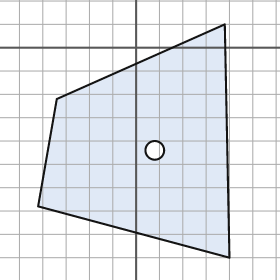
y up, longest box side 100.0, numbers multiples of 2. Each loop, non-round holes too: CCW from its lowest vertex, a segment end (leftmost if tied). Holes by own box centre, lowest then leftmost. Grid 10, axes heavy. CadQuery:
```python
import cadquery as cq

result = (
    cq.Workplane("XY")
    .moveTo(40.0, -90.0)
    .lineTo(38.0, 10.0)
    .lineTo(-34.0, -22.0)
    .lineTo(-42.0, -68.0)
    .close()
    .moveTo(8.0, -44.0)
    .circle(4.0)
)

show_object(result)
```